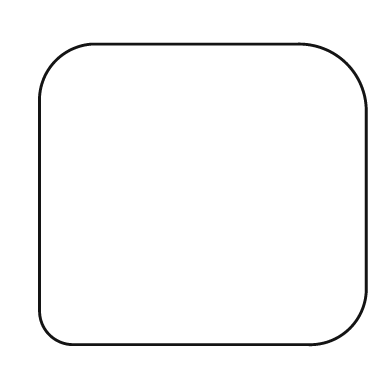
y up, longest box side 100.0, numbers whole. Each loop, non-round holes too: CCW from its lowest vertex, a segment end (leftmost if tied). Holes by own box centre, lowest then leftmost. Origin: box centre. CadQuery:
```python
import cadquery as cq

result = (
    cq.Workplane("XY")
    .moveTo(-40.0, -46.0)
    .lineTo(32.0, -46.0)
    .threePointArc((45.0, -41.0), (50.0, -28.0))
    .lineTo(50.0, 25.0)
    .threePointArc((44.0, 40.0), (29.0, 46.0))
    .lineTo(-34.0, 46.0)
    .threePointArc((-45.0, 41.0), (-50.0, 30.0))
    .lineTo(-50.0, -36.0)
    .threePointArc((-47.0, -43.0), (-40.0, -46.0))
    .close()
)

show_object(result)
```